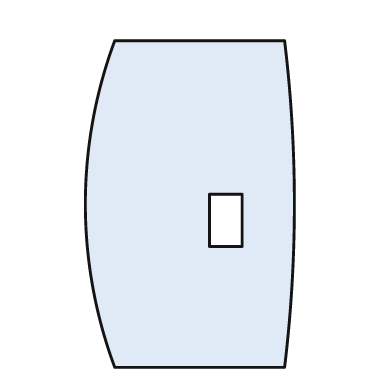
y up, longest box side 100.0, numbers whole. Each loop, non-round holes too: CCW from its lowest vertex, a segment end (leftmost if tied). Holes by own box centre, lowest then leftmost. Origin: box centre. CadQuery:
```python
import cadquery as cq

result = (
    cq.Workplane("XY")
    .moveTo(-23.0, -50.0)
    .lineTo(29.0, -50.0)
    .threePointArc((32.0, 0.0), (29.0, 50.0))
    .lineTo(-23.0, 50.0)
    .threePointArc((-32.0, 0.0), (-23.0, -50.0))
    .close()
    .moveTo(6.0, -13.0)
    .lineTo(16.0, -13.0)
    .lineTo(16.0, 3.0)
    .lineTo(6.0, 3.0)
    .close()
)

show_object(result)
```